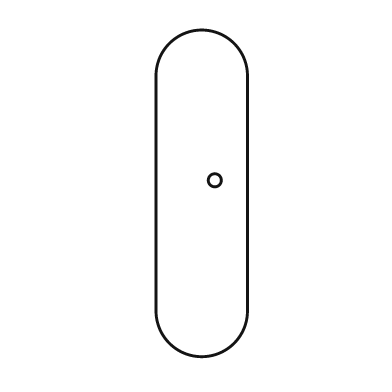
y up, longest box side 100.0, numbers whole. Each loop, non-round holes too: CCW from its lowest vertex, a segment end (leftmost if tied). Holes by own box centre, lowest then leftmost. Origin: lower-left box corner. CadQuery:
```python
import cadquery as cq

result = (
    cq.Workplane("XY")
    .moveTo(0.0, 14.0)
    .threePointArc((14.0, 0.0), (28.0, 14.0))
    .lineTo(28.0, 86.0)
    .threePointArc((14.0, 100.0), (0.0, 86.0))
    .close()
    .moveTo(18.0, 54.0)
    .circle(2.0)
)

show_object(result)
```